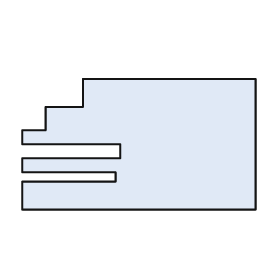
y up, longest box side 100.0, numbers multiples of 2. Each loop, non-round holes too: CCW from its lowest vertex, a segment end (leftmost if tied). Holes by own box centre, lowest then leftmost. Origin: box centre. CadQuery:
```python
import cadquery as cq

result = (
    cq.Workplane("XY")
    .moveTo(-50.0, -28.0)
    .lineTo(50.0, -28.0)
    .lineTo(50.0, 28.0)
    .lineTo(-24.0, 28.0)
    .lineTo(-24.0, 16.0)
    .lineTo(-40.0, 16.0)
    .lineTo(-40.0, 6.0)
    .lineTo(-50.0, 6.0)
    .lineTo(-50.0, 0.0)
    .lineTo(-8.0, 0.0)
    .lineTo(-8.0, -6.0)
    .lineTo(-50.0, -6.0)
    .lineTo(-50.0, -12.0)
    .lineTo(-10.0, -12.0)
    .lineTo(-10.0, -16.0)
    .lineTo(-50.0, -16.0)
    .close()
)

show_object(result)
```